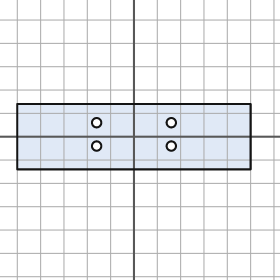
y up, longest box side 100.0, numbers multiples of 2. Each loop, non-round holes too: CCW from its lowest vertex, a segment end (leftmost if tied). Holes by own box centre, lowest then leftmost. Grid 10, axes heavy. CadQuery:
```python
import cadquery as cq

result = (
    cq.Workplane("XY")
    .moveTo(-50.0, -14.0)
    .lineTo(50.0, -14.0)
    .lineTo(50.0, 14.0)
    .lineTo(-50.0, 14.0)
    .close()
    .moveTo(-16.0, -4.0)
    .circle(2.0)
    .moveTo(16.0, -4.0)
    .circle(2.0)
    .moveTo(-16.0, 6.0)
    .circle(2.0)
    .moveTo(16.0, 6.0)
    .circle(2.0)
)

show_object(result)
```